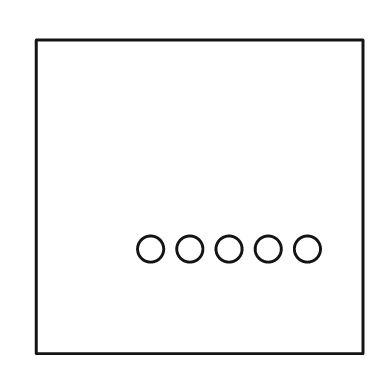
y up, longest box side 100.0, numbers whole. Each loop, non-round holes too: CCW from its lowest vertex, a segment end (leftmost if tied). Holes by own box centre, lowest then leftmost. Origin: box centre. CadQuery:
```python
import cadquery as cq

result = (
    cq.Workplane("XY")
    .moveTo(-50.0, -48.0)
    .lineTo(50.0, -48.0)
    .lineTo(50.0, 48.0)
    .lineTo(-50.0, 48.0)
    .close()
    .moveTo(-15.0, -16.0)
    .circle(4.0)
    .moveTo(-3.0, -16.0)
    .circle(4.0)
    .moveTo(9.0, -16.0)
    .circle(4.0)
    .moveTo(21.0, -16.0)
    .circle(4.0)
    .moveTo(33.0, -16.0)
    .circle(4.0)
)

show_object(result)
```